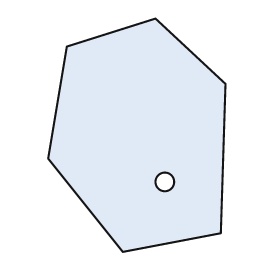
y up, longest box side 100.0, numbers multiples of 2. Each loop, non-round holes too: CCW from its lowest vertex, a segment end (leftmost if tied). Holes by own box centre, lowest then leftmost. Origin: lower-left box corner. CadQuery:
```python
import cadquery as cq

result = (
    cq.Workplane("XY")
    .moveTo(32.0, 0.0)
    .lineTo(74.0, 8.0)
    .lineTo(76.0, 72.0)
    .lineTo(46.0, 100.0)
    .lineTo(8.0, 88.0)
    .lineTo(0.0, 40.0)
    .close()
    .moveTo(50.0, 30.0)
    .circle(4.0)
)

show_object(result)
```